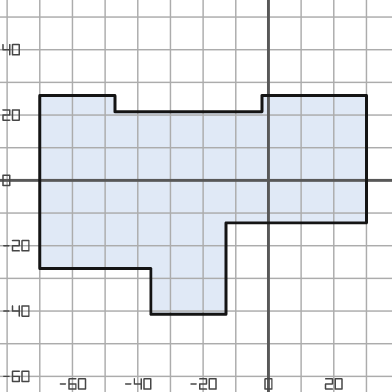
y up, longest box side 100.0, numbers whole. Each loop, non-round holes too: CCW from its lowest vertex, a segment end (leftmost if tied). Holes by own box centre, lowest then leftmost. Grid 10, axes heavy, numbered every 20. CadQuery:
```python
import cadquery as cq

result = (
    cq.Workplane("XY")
    .moveTo(-36.0, -41.0)
    .lineTo(-13.0, -41.0)
    .lineTo(-13.0, -13.0)
    .lineTo(30.0, -13.0)
    .lineTo(30.0, 26.0)
    .lineTo(-2.0, 26.0)
    .lineTo(-2.0, 21.0)
    .lineTo(-47.0, 21.0)
    .lineTo(-47.0, 26.0)
    .lineTo(-70.0, 26.0)
    .lineTo(-70.0, -27.0)
    .lineTo(-36.0, -27.0)
    .close()
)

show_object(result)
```